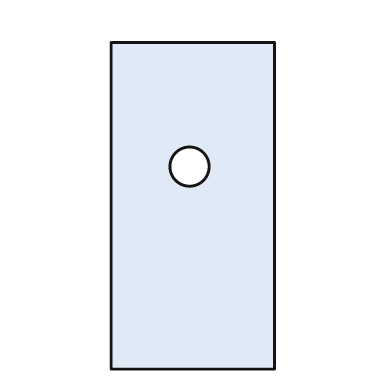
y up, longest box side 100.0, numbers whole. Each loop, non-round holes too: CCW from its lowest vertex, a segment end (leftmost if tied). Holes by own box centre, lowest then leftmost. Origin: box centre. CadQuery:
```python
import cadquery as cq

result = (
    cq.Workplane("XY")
    .moveTo(-25.0, -50.0)
    .lineTo(25.0, -50.0)
    .lineTo(25.0, 50.0)
    .lineTo(-25.0, 50.0)
    .close()
    .moveTo(-1.0, 12.0)
    .circle(6.0)
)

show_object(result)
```